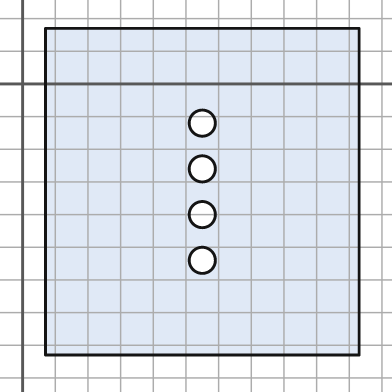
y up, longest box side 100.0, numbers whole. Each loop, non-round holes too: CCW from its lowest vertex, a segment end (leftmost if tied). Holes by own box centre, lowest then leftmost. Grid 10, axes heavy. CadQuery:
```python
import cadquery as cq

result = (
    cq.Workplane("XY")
    .moveTo(7.0, -83.0)
    .lineTo(103.0, -83.0)
    .lineTo(103.0, 17.0)
    .lineTo(7.0, 17.0)
    .close()
    .moveTo(55.0, -54.0)
    .circle(4.0)
    .moveTo(55.0, -40.0)
    .circle(4.0)
    .moveTo(55.0, -26.0)
    .circle(4.0)
    .moveTo(55.0, -12.0)
    .circle(4.0)
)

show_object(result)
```